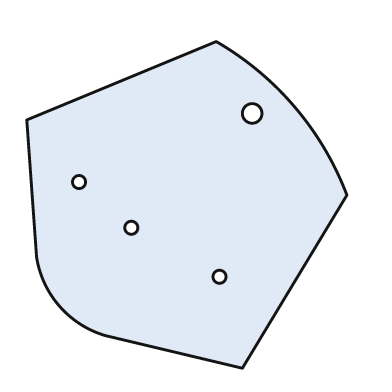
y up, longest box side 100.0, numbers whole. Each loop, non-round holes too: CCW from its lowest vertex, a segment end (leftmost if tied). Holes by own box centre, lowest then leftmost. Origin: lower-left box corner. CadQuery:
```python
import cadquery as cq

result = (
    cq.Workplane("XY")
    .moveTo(66.0, 0.0)
    .lineTo(98.0, 53.0)
    .threePointArc((82.0, 80.0), (58.0, 100.0))
    .lineTo(0.0, 76.0)
    .lineTo(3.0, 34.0)
    .threePointArc((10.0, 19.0), (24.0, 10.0))
    .close()
    .moveTo(59.0, 28.0)
    .circle(2.0)
    .moveTo(32.0, 43.0)
    .circle(2.0)
    .moveTo(16.0, 57.0)
    .circle(2.0)
    .moveTo(69.0, 78.0)
    .circle(3.0)
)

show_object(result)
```